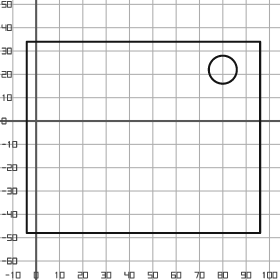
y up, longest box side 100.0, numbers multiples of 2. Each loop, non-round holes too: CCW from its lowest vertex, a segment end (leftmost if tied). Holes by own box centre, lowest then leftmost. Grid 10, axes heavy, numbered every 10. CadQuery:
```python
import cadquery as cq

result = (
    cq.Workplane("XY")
    .moveTo(-4.0, -48.0)
    .lineTo(96.0, -48.0)
    .lineTo(96.0, 34.0)
    .lineTo(-4.0, 34.0)
    .close()
    .moveTo(80.0, 22.0)
    .circle(6.0)
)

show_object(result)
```